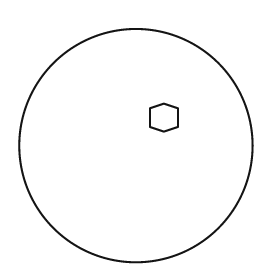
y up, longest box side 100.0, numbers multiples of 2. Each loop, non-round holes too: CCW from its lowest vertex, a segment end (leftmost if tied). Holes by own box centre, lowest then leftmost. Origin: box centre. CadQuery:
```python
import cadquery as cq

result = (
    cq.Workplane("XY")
    .moveTo(0.0, 0.0)
    .circle(50.0)
    .moveTo(12.0, 6.0)
    .lineTo(18.0, 8.0)
    .lineTo(18.0, 16.0)
    .lineTo(12.0, 18.0)
    .lineTo(6.0, 16.0)
    .lineTo(6.0, 8.0)
    .close()
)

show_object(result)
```